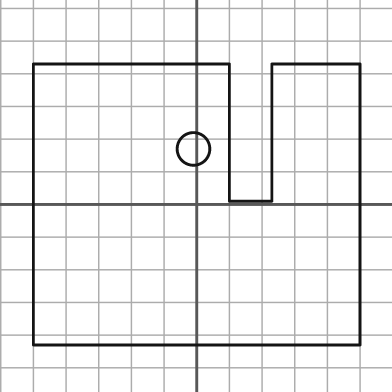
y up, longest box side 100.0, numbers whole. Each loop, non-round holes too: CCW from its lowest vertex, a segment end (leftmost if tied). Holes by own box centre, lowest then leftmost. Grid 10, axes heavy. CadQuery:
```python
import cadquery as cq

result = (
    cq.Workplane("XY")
    .moveTo(-50.0, -43.0)
    .lineTo(50.0, -43.0)
    .lineTo(50.0, 43.0)
    .lineTo(23.0, 43.0)
    .lineTo(23.0, 1.0)
    .lineTo(10.0, 1.0)
    .lineTo(10.0, 43.0)
    .lineTo(-50.0, 43.0)
    .close()
    .moveTo(-1.0, 17.0)
    .circle(5.0)
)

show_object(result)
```